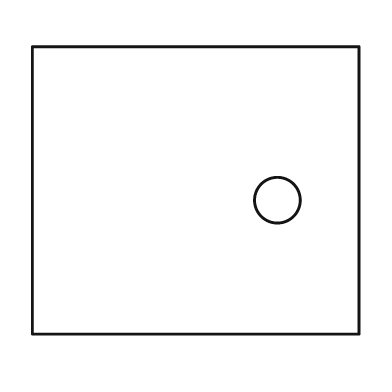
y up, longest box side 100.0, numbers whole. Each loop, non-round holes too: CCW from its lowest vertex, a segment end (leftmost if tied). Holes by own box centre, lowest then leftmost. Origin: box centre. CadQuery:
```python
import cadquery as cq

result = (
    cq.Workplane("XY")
    .moveTo(-50.0, -44.0)
    .lineTo(50.0, -44.0)
    .lineTo(50.0, 44.0)
    .lineTo(-50.0, 44.0)
    .close()
    .moveTo(25.0, -3.0)
    .circle(7.0)
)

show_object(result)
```